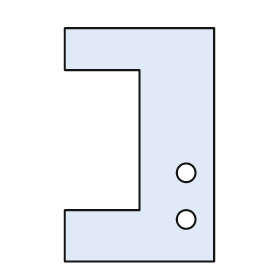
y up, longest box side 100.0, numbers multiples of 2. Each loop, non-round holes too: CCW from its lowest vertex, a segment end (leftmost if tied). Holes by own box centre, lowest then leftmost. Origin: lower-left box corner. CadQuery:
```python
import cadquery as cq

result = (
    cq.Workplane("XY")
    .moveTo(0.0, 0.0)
    .lineTo(64.0, 0.0)
    .lineTo(64.0, 100.0)
    .lineTo(0.0, 100.0)
    .lineTo(0.0, 82.0)
    .lineTo(32.0, 82.0)
    .lineTo(32.0, 22.0)
    .lineTo(0.0, 22.0)
    .close()
    .moveTo(52.0, 18.0)
    .circle(4.0)
    .moveTo(52.0, 38.0)
    .circle(4.0)
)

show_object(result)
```